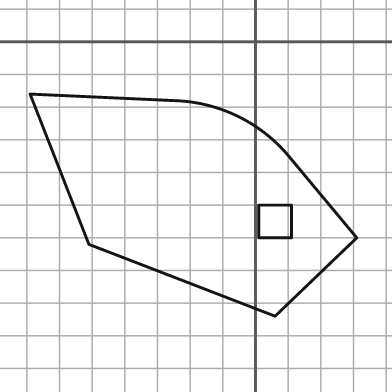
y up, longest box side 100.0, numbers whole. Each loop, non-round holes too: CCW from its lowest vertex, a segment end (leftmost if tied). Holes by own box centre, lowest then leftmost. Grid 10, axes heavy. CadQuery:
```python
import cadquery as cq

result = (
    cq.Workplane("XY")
    .moveTo(6.0, -84.0)
    .lineTo(31.0, -60.0)
    .lineTo(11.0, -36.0)
    .threePointArc((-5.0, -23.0), (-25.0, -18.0))
    .lineTo(-69.0, -16.0)
    .lineTo(-51.0, -62.0)
    .close()
    .moveTo(1.0, -60.0)
    .lineTo(11.0, -60.0)
    .lineTo(11.0, -50.0)
    .lineTo(1.0, -50.0)
    .close()
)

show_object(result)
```